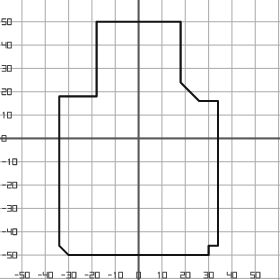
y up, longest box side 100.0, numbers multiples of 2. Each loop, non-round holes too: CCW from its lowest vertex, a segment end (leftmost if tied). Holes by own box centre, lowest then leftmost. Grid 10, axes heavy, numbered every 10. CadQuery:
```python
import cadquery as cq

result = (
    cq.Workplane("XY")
    .moveTo(-30.0, -50.0)
    .lineTo(30.0, -50.0)
    .lineTo(30.0, -46.0)
    .lineTo(34.0, -46.0)
    .lineTo(34.0, 16.0)
    .lineTo(26.0, 16.0)
    .lineTo(18.0, 24.0)
    .lineTo(18.0, 50.0)
    .lineTo(-18.0, 50.0)
    .lineTo(-18.0, 18.0)
    .lineTo(-34.0, 18.0)
    .lineTo(-34.0, -46.0)
    .close()
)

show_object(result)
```